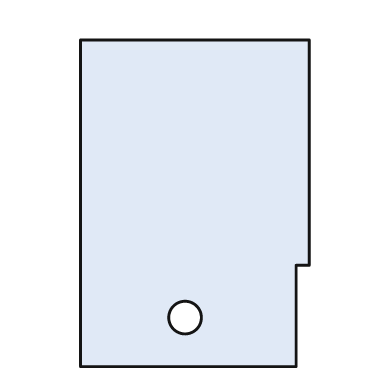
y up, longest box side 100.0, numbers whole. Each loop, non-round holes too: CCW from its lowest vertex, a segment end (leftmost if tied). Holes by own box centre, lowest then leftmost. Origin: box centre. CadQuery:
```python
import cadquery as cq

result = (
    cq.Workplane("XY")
    .moveTo(-35.0, -50.0)
    .lineTo(31.0, -50.0)
    .lineTo(31.0, -19.0)
    .lineTo(35.0, -19.0)
    .lineTo(35.0, 50.0)
    .lineTo(-35.0, 50.0)
    .close()
    .moveTo(-3.0, -35.0)
    .circle(5.0)
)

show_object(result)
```